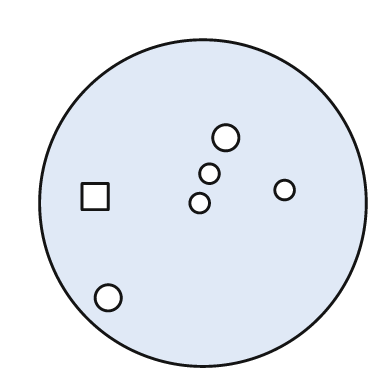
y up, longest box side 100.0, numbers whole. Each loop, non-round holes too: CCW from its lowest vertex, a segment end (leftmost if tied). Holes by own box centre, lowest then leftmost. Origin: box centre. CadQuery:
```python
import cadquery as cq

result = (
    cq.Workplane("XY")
    .moveTo(0.0, 0.0)
    .circle(50.0)
    .moveTo(-29.0, -29.0)
    .circle(4.0)
    .moveTo(-1.0, 0.0)
    .circle(3.0)
    .moveTo(-37.0, -2.0)
    .lineTo(-29.0, -2.0)
    .lineTo(-29.0, 6.0)
    .lineTo(-37.0, 6.0)
    .close()
    .moveTo(25.0, 4.0)
    .circle(3.0)
    .moveTo(2.0, 9.0)
    .circle(3.0)
    .moveTo(7.0, 20.0)
    .circle(4.0)
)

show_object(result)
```